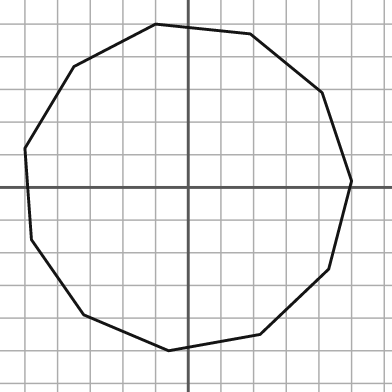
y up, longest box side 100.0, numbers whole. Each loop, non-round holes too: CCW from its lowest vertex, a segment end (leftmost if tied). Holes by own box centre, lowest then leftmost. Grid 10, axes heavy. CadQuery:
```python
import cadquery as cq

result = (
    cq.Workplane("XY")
    .moveTo(-6.0, -50.0)
    .lineTo(22.0, -45.0)
    .lineTo(43.0, -25.0)
    .lineTo(50.0, 2.0)
    .lineTo(41.0, 29.0)
    .lineTo(19.0, 47.0)
    .lineTo(-10.0, 50.0)
    .lineTo(-35.0, 37.0)
    .lineTo(-50.0, 12.0)
    .lineTo(-48.0, -16.0)
    .lineTo(-32.0, -39.0)
    .close()
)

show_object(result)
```